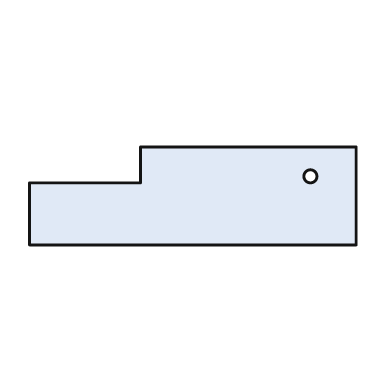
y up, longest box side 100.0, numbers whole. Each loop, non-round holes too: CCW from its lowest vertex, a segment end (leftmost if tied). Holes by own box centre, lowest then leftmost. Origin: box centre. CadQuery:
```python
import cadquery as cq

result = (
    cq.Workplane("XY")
    .moveTo(-50.0, -15.0)
    .lineTo(50.0, -15.0)
    .lineTo(50.0, 15.0)
    .lineTo(-16.0, 15.0)
    .lineTo(-16.0, 4.0)
    .lineTo(-50.0, 4.0)
    .close()
    .moveTo(36.0, 6.0)
    .circle(2.0)
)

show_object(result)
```